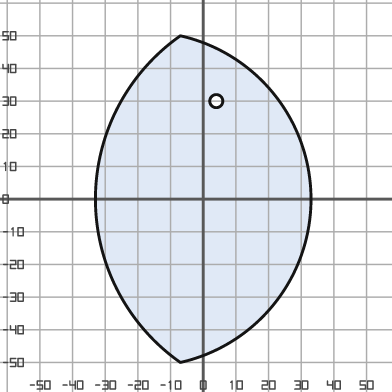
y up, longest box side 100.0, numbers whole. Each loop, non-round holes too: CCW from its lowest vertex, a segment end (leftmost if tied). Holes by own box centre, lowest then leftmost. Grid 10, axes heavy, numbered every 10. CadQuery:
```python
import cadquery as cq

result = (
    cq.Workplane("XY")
    .moveTo(-7.0, -50.0)
    .threePointArc((33.0, 0.0), (-7.0, 50.0))
    .threePointArc((-33.0, 0.0), (-7.0, -50.0))
    .close()
    .moveTo(4.0, 30.0)
    .circle(2.0)
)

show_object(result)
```